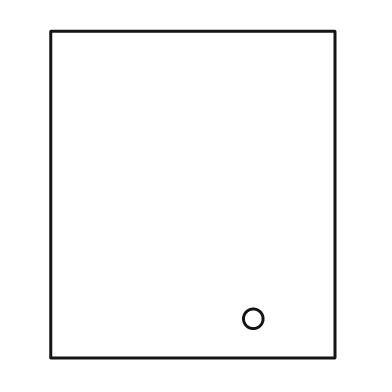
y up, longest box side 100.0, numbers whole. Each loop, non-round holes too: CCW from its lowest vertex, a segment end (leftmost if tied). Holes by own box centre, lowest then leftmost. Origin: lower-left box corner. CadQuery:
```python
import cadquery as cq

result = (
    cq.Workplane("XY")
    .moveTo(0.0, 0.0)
    .lineTo(87.0, 0.0)
    .lineTo(87.0, 100.0)
    .lineTo(0.0, 100.0)
    .close()
    .moveTo(62.0, 12.0)
    .circle(3.0)
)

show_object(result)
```